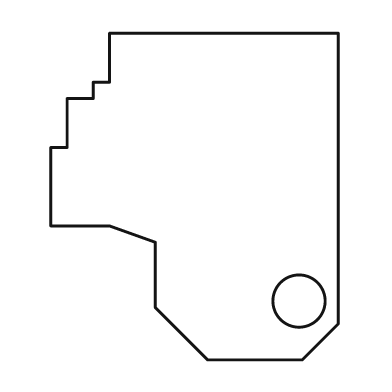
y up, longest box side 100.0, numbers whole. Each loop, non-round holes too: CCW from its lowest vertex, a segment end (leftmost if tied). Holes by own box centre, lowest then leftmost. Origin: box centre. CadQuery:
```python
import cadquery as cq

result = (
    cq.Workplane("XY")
    .moveTo(4.0, -50.0)
    .lineTo(33.0, -50.0)
    .lineTo(44.0, -39.0)
    .lineTo(44.0, 50.0)
    .lineTo(-26.0, 50.0)
    .lineTo(-26.0, 35.0)
    .lineTo(-31.0, 35.0)
    .lineTo(-31.0, 30.0)
    .lineTo(-39.0, 30.0)
    .lineTo(-39.0, 15.0)
    .lineTo(-44.0, 15.0)
    .lineTo(-44.0, -9.0)
    .lineTo(-26.0, -9.0)
    .lineTo(-12.0, -14.0)
    .lineTo(-12.0, -34.0)
    .close()
    .moveTo(32.0, -32.0)
    .circle(8.0)
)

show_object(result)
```